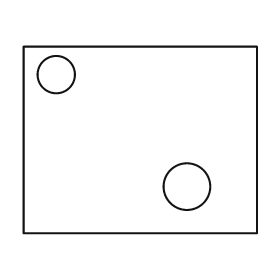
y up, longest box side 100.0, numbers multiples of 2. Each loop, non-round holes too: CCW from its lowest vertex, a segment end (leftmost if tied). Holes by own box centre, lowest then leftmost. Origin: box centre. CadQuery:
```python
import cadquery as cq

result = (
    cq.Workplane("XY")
    .moveTo(-50.0, -40.0)
    .lineTo(50.0, -40.0)
    .lineTo(50.0, 40.0)
    .lineTo(-50.0, 40.0)
    .close()
    .moveTo(20.0, -20.0)
    .circle(10.0)
    .moveTo(-36.0, 28.0)
    .circle(8.0)
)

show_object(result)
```